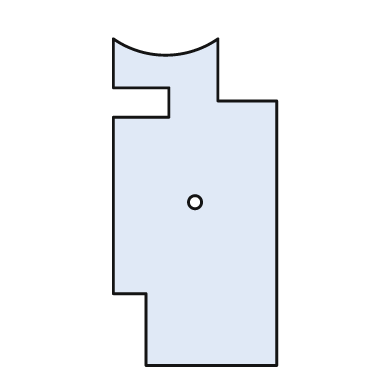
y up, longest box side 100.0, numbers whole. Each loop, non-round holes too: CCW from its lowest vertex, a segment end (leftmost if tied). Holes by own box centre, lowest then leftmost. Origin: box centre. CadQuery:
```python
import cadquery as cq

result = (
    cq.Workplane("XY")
    .moveTo(-15.0, -50.0)
    .lineTo(25.0, -50.0)
    .lineTo(25.0, 31.0)
    .lineTo(7.0, 31.0)
    .lineTo(7.0, 50.0)
    .threePointArc((-9.0, 45.0), (-25.0, 50.0))
    .lineTo(-25.0, 35.0)
    .lineTo(-8.0, 35.0)
    .lineTo(-8.0, 26.0)
    .lineTo(-25.0, 26.0)
    .lineTo(-25.0, -28.0)
    .lineTo(-15.0, -28.0)
    .close()
    .moveTo(0.0, 0.0)
    .circle(2.0)
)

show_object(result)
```